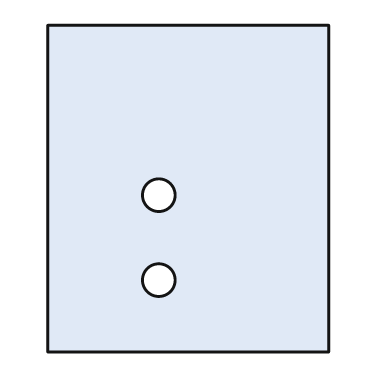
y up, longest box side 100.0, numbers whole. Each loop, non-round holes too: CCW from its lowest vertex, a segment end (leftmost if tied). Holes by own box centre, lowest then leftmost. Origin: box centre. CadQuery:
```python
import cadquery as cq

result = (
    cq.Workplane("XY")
    .moveTo(-43.0, -50.0)
    .lineTo(43.0, -50.0)
    .lineTo(43.0, 50.0)
    .lineTo(-43.0, 50.0)
    .close()
    .moveTo(-9.0, -28.0)
    .circle(5.0)
    .moveTo(-9.0, -2.0)
    .circle(5.0)
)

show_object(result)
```